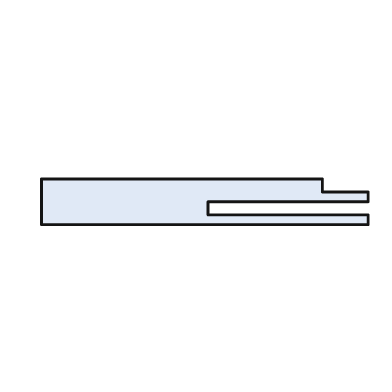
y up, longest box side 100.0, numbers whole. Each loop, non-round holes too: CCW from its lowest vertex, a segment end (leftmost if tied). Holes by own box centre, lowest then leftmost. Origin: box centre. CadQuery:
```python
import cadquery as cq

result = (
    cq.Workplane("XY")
    .moveTo(-50.0, -7.0)
    .lineTo(50.0, -7.0)
    .lineTo(50.0, -4.0)
    .lineTo(1.0, -4.0)
    .lineTo(1.0, 0.0)
    .lineTo(50.0, 0.0)
    .lineTo(50.0, 3.0)
    .lineTo(36.0, 3.0)
    .lineTo(36.0, 7.0)
    .lineTo(-50.0, 7.0)
    .close()
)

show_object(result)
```